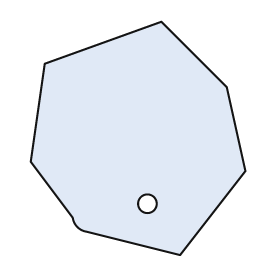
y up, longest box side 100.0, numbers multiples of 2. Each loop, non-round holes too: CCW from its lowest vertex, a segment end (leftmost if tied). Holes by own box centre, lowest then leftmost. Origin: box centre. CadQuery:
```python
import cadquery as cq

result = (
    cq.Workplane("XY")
    .moveTo(18.0, -50.0)
    .lineTo(46.0, -14.0)
    .lineTo(38.0, 22.0)
    .lineTo(10.0, 50.0)
    .lineTo(-40.0, 32.0)
    .lineTo(-46.0, -10.0)
    .lineTo(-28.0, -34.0)
    .threePointArc((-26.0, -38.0), (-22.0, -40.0))
    .close()
    .moveTo(4.0, -28.0)
    .circle(4.0)
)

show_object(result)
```